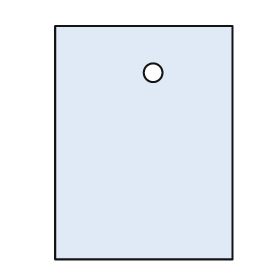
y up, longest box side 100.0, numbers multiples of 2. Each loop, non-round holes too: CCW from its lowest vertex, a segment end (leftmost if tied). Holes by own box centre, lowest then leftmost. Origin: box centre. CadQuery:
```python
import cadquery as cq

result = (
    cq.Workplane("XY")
    .moveTo(-38.0, -50.0)
    .lineTo(38.0, -50.0)
    .lineTo(38.0, 50.0)
    .lineTo(-38.0, 50.0)
    .close()
    .moveTo(4.0, 30.0)
    .circle(4.0)
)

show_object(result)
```